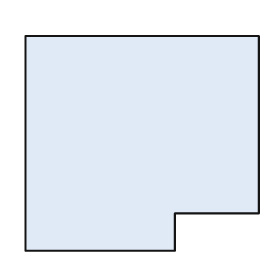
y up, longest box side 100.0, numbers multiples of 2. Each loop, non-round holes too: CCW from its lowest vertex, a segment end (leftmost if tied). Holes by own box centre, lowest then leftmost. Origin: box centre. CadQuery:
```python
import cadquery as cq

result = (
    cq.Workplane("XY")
    .moveTo(-50.0, -46.0)
    .lineTo(14.0, -46.0)
    .lineTo(14.0, -30.0)
    .lineTo(50.0, -30.0)
    .lineTo(50.0, 46.0)
    .lineTo(-50.0, 46.0)
    .close()
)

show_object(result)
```